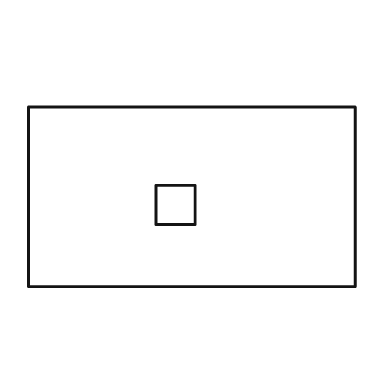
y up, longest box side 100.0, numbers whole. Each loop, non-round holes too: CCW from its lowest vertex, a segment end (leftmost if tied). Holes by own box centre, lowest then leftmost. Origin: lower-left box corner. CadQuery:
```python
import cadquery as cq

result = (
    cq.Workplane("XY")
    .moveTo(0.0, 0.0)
    .lineTo(100.0, 0.0)
    .lineTo(100.0, 55.0)
    .lineTo(0.0, 55.0)
    .close()
    .moveTo(39.0, 19.0)
    .lineTo(51.0, 19.0)
    .lineTo(51.0, 31.0)
    .lineTo(39.0, 31.0)
    .close()
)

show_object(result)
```